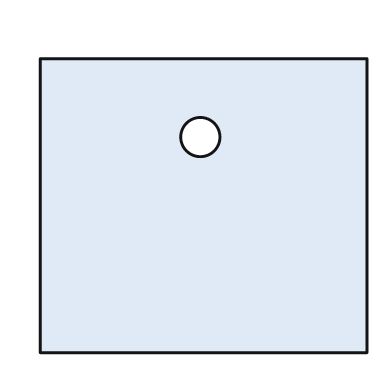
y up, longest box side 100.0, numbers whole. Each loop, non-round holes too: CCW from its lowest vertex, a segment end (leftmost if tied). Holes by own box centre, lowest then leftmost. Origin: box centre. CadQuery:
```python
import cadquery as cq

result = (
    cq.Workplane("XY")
    .moveTo(-50.0, -45.0)
    .lineTo(50.0, -45.0)
    .lineTo(50.0, 45.0)
    .lineTo(-50.0, 45.0)
    .close()
    .moveTo(-1.0, 21.0)
    .circle(6.0)
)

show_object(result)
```